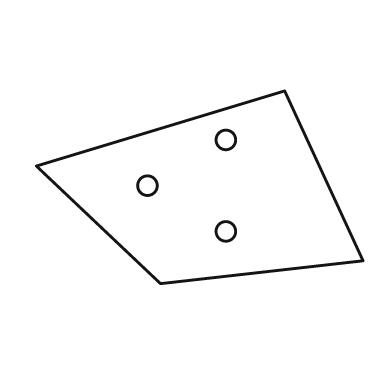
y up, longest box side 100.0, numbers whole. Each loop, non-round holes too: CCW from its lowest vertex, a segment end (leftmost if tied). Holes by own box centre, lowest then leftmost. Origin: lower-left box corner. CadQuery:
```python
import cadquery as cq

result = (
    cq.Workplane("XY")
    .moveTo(38.0, 0.0)
    .lineTo(100.0, 7.0)
    .lineTo(76.0, 59.0)
    .lineTo(0.0, 36.0)
    .close()
    .moveTo(58.0, 16.0)
    .circle(3.0)
    .moveTo(34.0, 30.0)
    .circle(3.0)
    .moveTo(58.0, 44.0)
    .circle(3.0)
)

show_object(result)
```